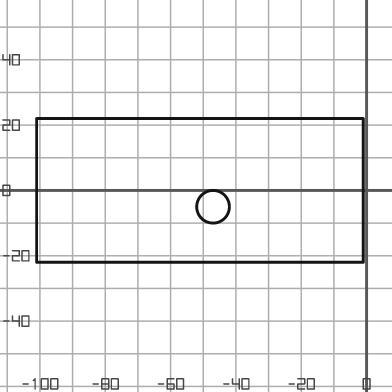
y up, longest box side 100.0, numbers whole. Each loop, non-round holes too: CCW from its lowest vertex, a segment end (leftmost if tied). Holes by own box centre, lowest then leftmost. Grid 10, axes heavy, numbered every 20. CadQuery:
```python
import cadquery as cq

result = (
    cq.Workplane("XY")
    .moveTo(-101.0, -22.0)
    .lineTo(-1.0, -22.0)
    .lineTo(-1.0, 22.0)
    .lineTo(-101.0, 22.0)
    .close()
    .moveTo(-47.0, -5.0)
    .circle(5.0)
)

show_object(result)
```